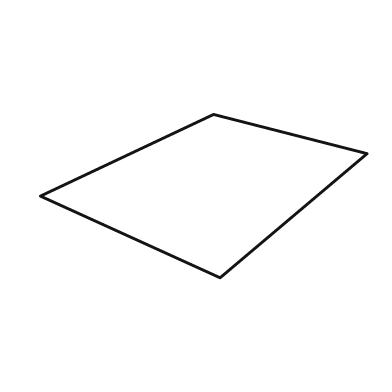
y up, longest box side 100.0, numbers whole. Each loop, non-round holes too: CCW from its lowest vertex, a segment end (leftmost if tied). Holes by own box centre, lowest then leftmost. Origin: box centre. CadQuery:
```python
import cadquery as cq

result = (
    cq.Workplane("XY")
    .moveTo(5.0, -25.0)
    .lineTo(50.0, 13.0)
    .lineTo(3.0, 25.0)
    .lineTo(-50.0, 0.0)
    .close()
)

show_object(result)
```